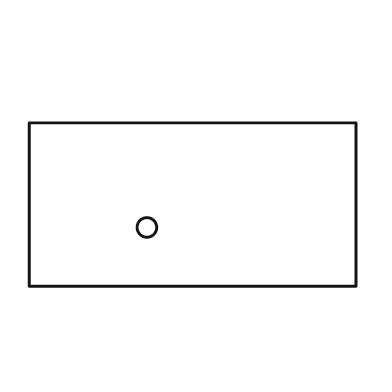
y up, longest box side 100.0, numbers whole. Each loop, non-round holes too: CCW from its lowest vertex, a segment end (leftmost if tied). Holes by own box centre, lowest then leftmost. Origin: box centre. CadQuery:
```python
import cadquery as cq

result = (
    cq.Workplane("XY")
    .moveTo(-50.0, -25.0)
    .lineTo(50.0, -25.0)
    .lineTo(50.0, 25.0)
    .lineTo(-50.0, 25.0)
    .close()
    .moveTo(-14.0, -7.0)
    .circle(3.0)
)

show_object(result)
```